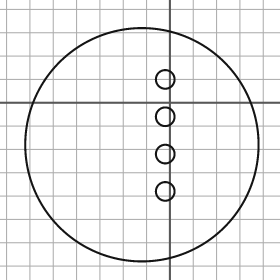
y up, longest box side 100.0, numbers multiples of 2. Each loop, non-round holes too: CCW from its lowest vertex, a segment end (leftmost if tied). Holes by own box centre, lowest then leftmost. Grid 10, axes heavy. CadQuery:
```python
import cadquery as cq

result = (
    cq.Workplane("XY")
    .moveTo(-12.0, -18.0)
    .circle(50.0)
    .moveTo(-2.0, -38.0)
    .circle(4.0)
    .moveTo(-2.0, -22.0)
    .circle(4.0)
    .moveTo(-2.0, -6.0)
    .circle(4.0)
    .moveTo(-2.0, 10.0)
    .circle(4.0)
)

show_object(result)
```